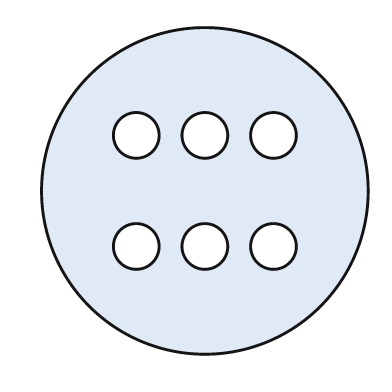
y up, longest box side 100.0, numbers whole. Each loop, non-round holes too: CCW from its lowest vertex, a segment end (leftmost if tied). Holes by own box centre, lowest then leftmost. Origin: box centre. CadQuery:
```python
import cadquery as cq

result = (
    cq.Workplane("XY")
    .moveTo(0.0, 0.0)
    .circle(50.0)
    .moveTo(-21.0, -17.0)
    .circle(7.0)
    .moveTo(0.0, -17.0)
    .circle(7.0)
    .moveTo(21.0, -17.0)
    .circle(7.0)
    .moveTo(-21.0, 17.0)
    .circle(7.0)
    .moveTo(0.0, 17.0)
    .circle(7.0)
    .moveTo(21.0, 17.0)
    .circle(7.0)
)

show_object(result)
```